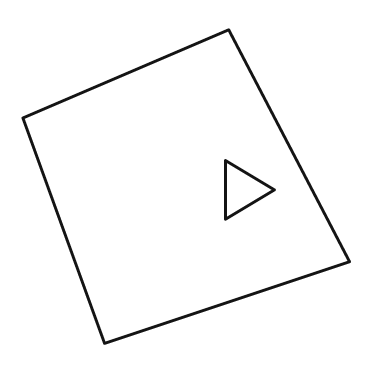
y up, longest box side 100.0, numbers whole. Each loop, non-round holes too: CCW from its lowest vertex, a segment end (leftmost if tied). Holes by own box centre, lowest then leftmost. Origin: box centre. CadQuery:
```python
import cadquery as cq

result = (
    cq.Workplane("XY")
    .moveTo(-25.0, -48.0)
    .lineTo(50.0, -23.0)
    .lineTo(13.0, 48.0)
    .lineTo(-50.0, 21.0)
    .close()
    .moveTo(12.0, -10.0)
    .lineTo(27.0, -1.0)
    .lineTo(12.0, 8.0)
    .close()
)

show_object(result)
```